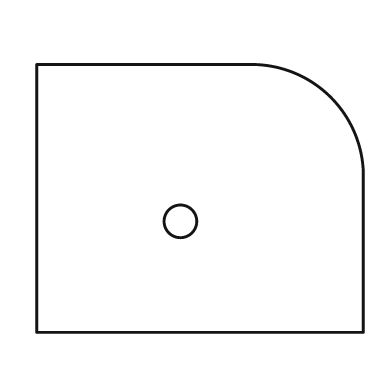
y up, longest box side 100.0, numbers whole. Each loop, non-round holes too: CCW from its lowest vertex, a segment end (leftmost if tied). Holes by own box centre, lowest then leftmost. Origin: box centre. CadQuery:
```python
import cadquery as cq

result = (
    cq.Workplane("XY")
    .moveTo(-50.0, -41.0)
    .lineTo(50.0, -41.0)
    .lineTo(50.0, 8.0)
    .threePointArc((40.0, 31.0), (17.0, 41.0))
    .lineTo(-50.0, 41.0)
    .close()
    .moveTo(-6.0, -7.0)
    .circle(5.0)
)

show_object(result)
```